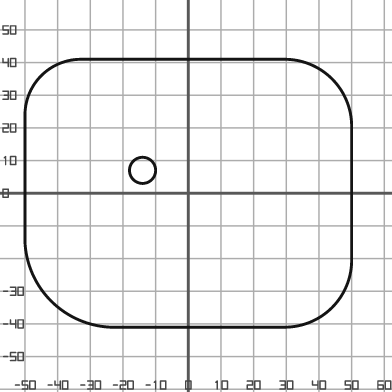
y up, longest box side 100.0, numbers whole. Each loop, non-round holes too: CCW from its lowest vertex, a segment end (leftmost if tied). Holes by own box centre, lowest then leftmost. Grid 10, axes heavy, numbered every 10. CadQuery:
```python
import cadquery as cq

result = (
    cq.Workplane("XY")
    .moveTo(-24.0, -41.0)
    .lineTo(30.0, -41.0)
    .threePointArc((44.0, -35.0), (50.0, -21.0))
    .lineTo(50.0, 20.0)
    .threePointArc((44.0, 35.0), (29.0, 41.0))
    .lineTo(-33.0, 41.0)
    .threePointArc((-45.0, 36.0), (-50.0, 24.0))
    .lineTo(-50.0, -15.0)
    .threePointArc((-42.0, -33.0), (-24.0, -41.0))
    .close()
    .moveTo(-14.0, 7.0)
    .circle(4.0)
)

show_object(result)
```